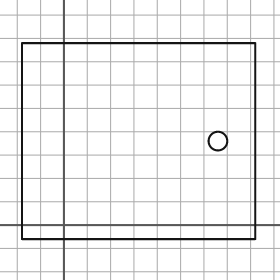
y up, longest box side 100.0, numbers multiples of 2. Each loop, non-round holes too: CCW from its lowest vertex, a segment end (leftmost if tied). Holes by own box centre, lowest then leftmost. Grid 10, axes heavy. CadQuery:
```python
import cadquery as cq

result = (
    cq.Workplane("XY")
    .moveTo(-18.0, -6.0)
    .lineTo(82.0, -6.0)
    .lineTo(82.0, 78.0)
    .lineTo(-18.0, 78.0)
    .close()
    .moveTo(66.0, 36.0)
    .circle(4.0)
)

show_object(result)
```